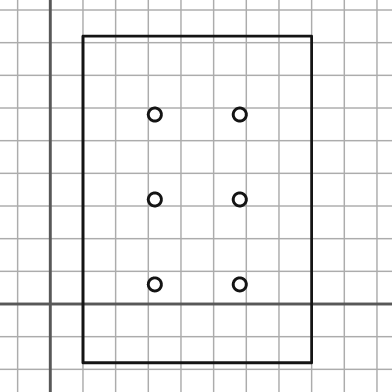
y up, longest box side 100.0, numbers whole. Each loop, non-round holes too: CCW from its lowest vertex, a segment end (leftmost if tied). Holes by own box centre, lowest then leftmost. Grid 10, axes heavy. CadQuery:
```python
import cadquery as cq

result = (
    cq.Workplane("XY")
    .moveTo(10.0, -18.0)
    .lineTo(80.0, -18.0)
    .lineTo(80.0, 82.0)
    .lineTo(10.0, 82.0)
    .close()
    .moveTo(32.0, 6.0)
    .circle(2.0)
    .moveTo(58.0, 6.0)
    .circle(2.0)
    .moveTo(32.0, 32.0)
    .circle(2.0)
    .moveTo(58.0, 32.0)
    .circle(2.0)
    .moveTo(32.0, 58.0)
    .circle(2.0)
    .moveTo(58.0, 58.0)
    .circle(2.0)
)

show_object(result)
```